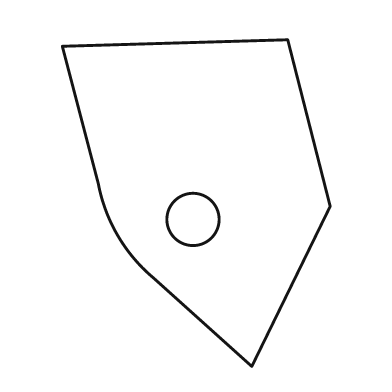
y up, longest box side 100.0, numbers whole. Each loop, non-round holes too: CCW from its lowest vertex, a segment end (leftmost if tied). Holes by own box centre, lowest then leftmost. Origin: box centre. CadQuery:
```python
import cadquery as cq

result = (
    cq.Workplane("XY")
    .moveTo(17.0, -50.0)
    .lineTo(41.0, -1.0)
    .lineTo(28.0, 50.0)
    .lineTo(-41.0, 48.0)
    .lineTo(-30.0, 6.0)
    .threePointArc((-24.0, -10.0), (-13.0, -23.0))
    .close()
    .moveTo(-1.0, -5.0)
    .circle(8.0)
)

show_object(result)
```